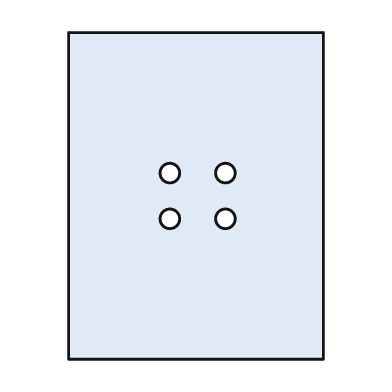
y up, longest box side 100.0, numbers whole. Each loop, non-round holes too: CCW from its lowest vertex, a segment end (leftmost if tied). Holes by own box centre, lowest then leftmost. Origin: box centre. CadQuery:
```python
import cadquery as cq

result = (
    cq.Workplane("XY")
    .moveTo(-39.0, -50.0)
    .lineTo(39.0, -50.0)
    .lineTo(39.0, 50.0)
    .lineTo(-39.0, 50.0)
    .close()
    .moveTo(-8.0, -7.0)
    .circle(3.0)
    .moveTo(9.0, -7.0)
    .circle(3.0)
    .moveTo(-8.0, 7.0)
    .circle(3.0)
    .moveTo(9.0, 7.0)
    .circle(3.0)
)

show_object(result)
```